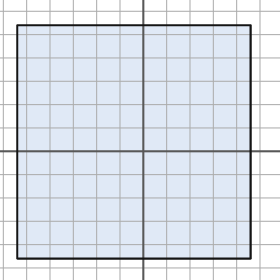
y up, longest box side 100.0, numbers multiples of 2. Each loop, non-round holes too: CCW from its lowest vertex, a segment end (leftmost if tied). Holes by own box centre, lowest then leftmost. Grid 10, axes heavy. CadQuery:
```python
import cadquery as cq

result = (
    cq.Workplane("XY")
    .moveTo(-54.0, -46.0)
    .lineTo(46.0, -46.0)
    .lineTo(46.0, 54.0)
    .lineTo(-54.0, 54.0)
    .close()
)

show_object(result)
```